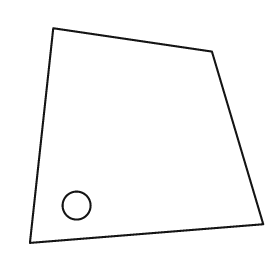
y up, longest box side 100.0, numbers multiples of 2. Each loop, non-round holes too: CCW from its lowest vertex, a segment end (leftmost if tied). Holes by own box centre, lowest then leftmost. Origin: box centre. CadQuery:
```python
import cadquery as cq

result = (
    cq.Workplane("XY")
    .moveTo(-50.0, -46.0)
    .lineTo(50.0, -38.0)
    .lineTo(28.0, 36.0)
    .lineTo(-40.0, 46.0)
    .close()
    .moveTo(-30.0, -30.0)
    .circle(6.0)
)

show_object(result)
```